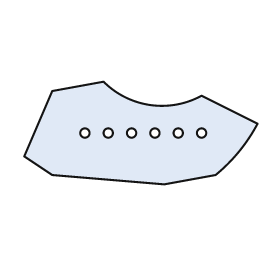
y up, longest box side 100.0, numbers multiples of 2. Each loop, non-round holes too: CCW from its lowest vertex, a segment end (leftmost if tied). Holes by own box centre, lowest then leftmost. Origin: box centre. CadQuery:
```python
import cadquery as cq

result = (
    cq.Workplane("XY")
    .moveTo(10.0, -22.0)
    .lineTo(32.0, -18.0)
    .threePointArc((42.0, -8.0), (50.0, 4.0))
    .lineTo(26.0, 16.0)
    .threePointArc((4.0, 12.0), (-16.0, 22.0))
    .lineTo(-38.0, 18.0)
    .lineTo(-50.0, -10.0)
    .lineTo(-38.0, -18.0)
    .close()
    .moveTo(-24.0, 0.0)
    .circle(2.0)
    .moveTo(-14.0, 0.0)
    .circle(2.0)
    .moveTo(-4.0, 0.0)
    .circle(2.0)
    .moveTo(6.0, 0.0)
    .circle(2.0)
    .moveTo(16.0, 0.0)
    .circle(2.0)
    .moveTo(26.0, 0.0)
    .circle(2.0)
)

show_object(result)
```